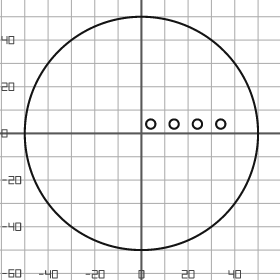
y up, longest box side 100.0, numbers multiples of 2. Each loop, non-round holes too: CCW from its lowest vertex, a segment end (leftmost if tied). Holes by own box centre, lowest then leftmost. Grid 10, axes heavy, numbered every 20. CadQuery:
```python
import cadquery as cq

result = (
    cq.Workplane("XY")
    .moveTo(0.0, 0.0)
    .circle(50.0)
    .moveTo(4.0, 4.0)
    .circle(2.0)
    .moveTo(14.0, 4.0)
    .circle(2.0)
    .moveTo(24.0, 4.0)
    .circle(2.0)
    .moveTo(34.0, 4.0)
    .circle(2.0)
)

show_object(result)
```